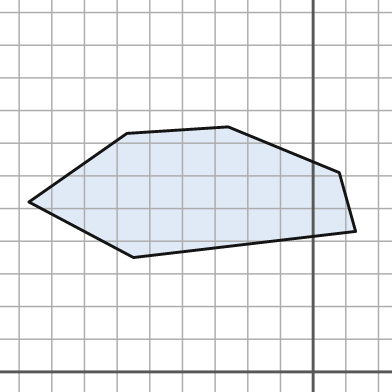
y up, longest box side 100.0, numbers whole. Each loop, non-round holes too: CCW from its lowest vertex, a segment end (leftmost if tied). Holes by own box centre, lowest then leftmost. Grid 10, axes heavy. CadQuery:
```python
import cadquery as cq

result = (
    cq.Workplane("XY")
    .moveTo(-55.0, 35.0)
    .lineTo(13.0, 43.0)
    .lineTo(8.0, 61.0)
    .lineTo(-26.0, 75.0)
    .lineTo(-57.0, 73.0)
    .lineTo(-87.0, 52.0)
    .close()
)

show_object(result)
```